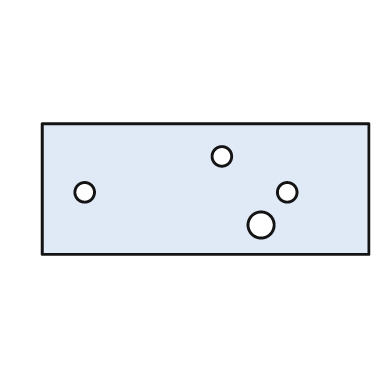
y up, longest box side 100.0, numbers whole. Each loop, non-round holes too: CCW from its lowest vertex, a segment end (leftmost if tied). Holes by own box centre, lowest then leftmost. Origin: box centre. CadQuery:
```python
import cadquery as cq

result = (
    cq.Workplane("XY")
    .moveTo(-50.0, -20.0)
    .lineTo(50.0, -20.0)
    .lineTo(50.0, 20.0)
    .lineTo(-50.0, 20.0)
    .close()
    .moveTo(17.0, -11.0)
    .circle(4.0)
    .moveTo(-37.0, -1.0)
    .circle(3.0)
    .moveTo(25.0, -1.0)
    .circle(3.0)
    .moveTo(5.0, 10.0)
    .circle(3.0)
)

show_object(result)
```